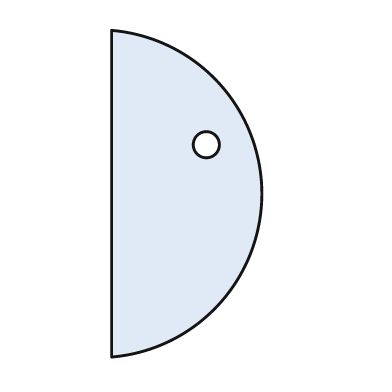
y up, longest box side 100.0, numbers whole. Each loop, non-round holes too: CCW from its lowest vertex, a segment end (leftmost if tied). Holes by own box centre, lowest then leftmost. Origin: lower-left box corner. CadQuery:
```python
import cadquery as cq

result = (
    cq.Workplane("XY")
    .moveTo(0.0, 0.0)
    .threePointArc((46.0, 50.0), (0.0, 100.0))
    .close()
    .moveTo(29.0, 65.0)
    .circle(4.0)
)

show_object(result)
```